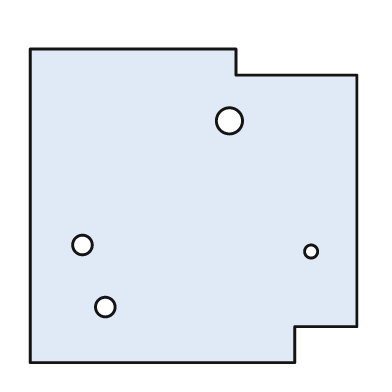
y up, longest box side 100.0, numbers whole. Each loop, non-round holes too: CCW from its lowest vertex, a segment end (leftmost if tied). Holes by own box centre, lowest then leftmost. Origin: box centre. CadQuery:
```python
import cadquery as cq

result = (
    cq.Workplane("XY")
    .moveTo(-50.0, -48.0)
    .lineTo(31.0, -48.0)
    .lineTo(31.0, -37.0)
    .lineTo(50.0, -37.0)
    .lineTo(50.0, 40.0)
    .lineTo(13.0, 40.0)
    .lineTo(13.0, 48.0)
    .lineTo(-50.0, 48.0)
    .close()
    .moveTo(-27.0, -31.0)
    .circle(3.0)
    .moveTo(36.0, -14.0)
    .circle(2.0)
    .moveTo(-34.0, -12.0)
    .circle(3.0)
    .moveTo(11.0, 26.0)
    .circle(4.0)
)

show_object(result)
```